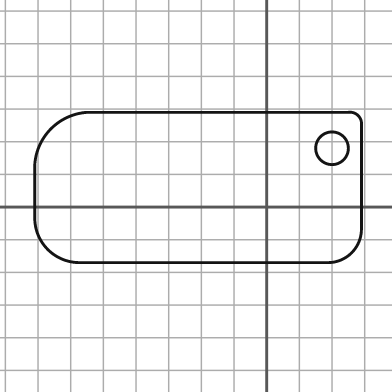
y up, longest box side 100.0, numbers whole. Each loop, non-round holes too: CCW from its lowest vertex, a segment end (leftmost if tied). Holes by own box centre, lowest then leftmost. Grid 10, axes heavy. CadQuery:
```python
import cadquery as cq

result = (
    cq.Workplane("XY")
    .moveTo(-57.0, -17.0)
    .lineTo(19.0, -17.0)
    .threePointArc((26.0, -14.0), (29.0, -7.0))
    .lineTo(29.0, 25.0)
    .threePointArc((28.0, 28.0), (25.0, 29.0))
    .lineTo(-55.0, 29.0)
    .threePointArc((-66.0, 24.0), (-71.0, 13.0))
    .lineTo(-71.0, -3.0)
    .threePointArc((-67.0, -13.0), (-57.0, -17.0))
    .close()
    .moveTo(20.0, 18.0)
    .circle(5.0)
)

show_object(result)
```